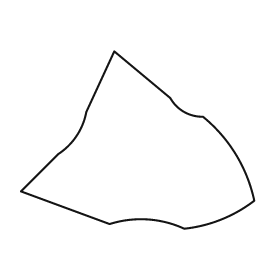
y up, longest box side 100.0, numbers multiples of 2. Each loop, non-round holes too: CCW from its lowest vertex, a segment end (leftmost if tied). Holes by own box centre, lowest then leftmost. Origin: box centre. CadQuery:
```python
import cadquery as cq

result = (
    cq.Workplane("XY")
    .moveTo(20.0, -38.0)
    .threePointArc((36.0, -34.0), (50.0, -26.0))
    .threePointArc((42.0, -6.0), (28.0, 10.0))
    .threePointArc((20.0, 12.0), (14.0, 18.0))
    .lineTo(-10.0, 38.0)
    .lineTo(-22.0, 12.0)
    .threePointArc((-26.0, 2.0), (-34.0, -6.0))
    .lineTo(-50.0, -22.0)
    .lineTo(-12.0, -36.0)
    .threePointArc((4.0, -34.0), (20.0, -38.0))
    .close()
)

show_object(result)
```